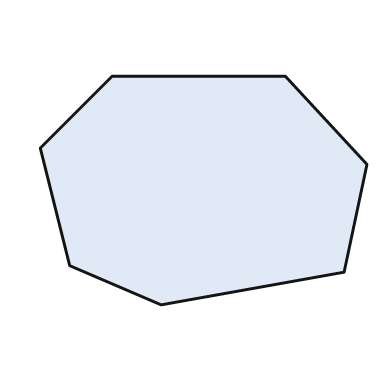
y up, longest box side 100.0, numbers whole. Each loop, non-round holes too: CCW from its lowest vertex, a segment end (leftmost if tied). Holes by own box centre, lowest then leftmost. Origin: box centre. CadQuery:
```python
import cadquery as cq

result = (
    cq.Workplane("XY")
    .moveTo(-13.0, -35.0)
    .lineTo(43.0, -25.0)
    .lineTo(50.0, 8.0)
    .lineTo(25.0, 35.0)
    .lineTo(-28.0, 35.0)
    .lineTo(-50.0, 13.0)
    .lineTo(-41.0, -23.0)
    .close()
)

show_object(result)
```